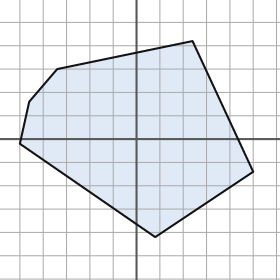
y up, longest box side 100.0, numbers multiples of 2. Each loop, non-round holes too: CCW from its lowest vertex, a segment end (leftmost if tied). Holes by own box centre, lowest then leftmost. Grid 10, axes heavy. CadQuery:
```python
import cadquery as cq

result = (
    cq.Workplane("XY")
    .moveTo(8.0, -42.0)
    .lineTo(50.0, -14.0)
    .lineTo(24.0, 42.0)
    .lineTo(-34.0, 30.0)
    .lineTo(-46.0, 16.0)
    .lineTo(-50.0, -2.0)
    .close()
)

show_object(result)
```